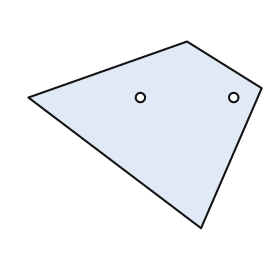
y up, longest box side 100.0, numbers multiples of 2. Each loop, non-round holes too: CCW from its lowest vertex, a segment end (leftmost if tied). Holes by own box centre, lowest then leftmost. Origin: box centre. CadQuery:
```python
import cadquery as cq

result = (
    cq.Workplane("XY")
    .moveTo(24.0, -40.0)
    .lineTo(50.0, 20.0)
    .lineTo(18.0, 40.0)
    .lineTo(-50.0, 16.0)
    .close()
    .moveTo(-2.0, 16.0)
    .circle(2.0)
    .moveTo(38.0, 16.0)
    .circle(2.0)
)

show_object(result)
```